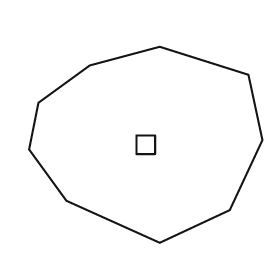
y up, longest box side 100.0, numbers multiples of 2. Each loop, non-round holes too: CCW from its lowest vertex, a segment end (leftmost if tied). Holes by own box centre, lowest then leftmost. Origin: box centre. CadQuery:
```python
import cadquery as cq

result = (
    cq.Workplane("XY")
    .moveTo(6.0, -42.0)
    .lineTo(36.0, -28.0)
    .lineTo(50.0, 2.0)
    .lineTo(44.0, 30.0)
    .lineTo(6.0, 42.0)
    .lineTo(-24.0, 34.0)
    .lineTo(-46.0, 18.0)
    .lineTo(-50.0, -2.0)
    .lineTo(-34.0, -24.0)
    .close()
    .moveTo(-4.0, -4.0)
    .lineTo(4.0, -4.0)
    .lineTo(4.0, 4.0)
    .lineTo(-4.0, 4.0)
    .close()
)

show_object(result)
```